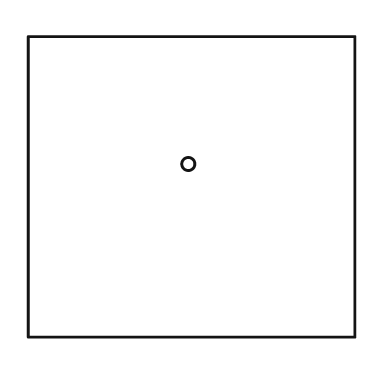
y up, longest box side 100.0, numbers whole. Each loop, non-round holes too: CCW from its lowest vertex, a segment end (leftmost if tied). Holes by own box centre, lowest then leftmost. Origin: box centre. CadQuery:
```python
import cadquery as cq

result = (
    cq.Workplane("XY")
    .moveTo(-50.0, -46.0)
    .lineTo(50.0, -46.0)
    .lineTo(50.0, 46.0)
    .lineTo(-50.0, 46.0)
    .close()
    .moveTo(-1.0, 7.0)
    .circle(2.0)
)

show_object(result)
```